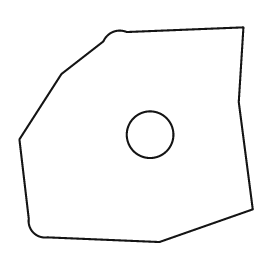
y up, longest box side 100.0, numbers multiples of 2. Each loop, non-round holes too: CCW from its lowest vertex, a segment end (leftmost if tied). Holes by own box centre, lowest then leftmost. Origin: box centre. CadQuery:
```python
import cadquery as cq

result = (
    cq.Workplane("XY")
    .moveTo(10.0, -46.0)
    .lineTo(50.0, -32.0)
    .lineTo(44.0, 14.0)
    .lineTo(46.0, 46.0)
    .lineTo(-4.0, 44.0)
    .threePointArc((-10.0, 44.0), (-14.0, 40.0))
    .lineTo(-32.0, 26.0)
    .lineTo(-50.0, -2.0)
    .lineTo(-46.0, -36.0)
    .threePointArc((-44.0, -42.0), (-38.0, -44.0))
    .close()
    .moveTo(6.0, 0.0)
    .circle(10.0)
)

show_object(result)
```